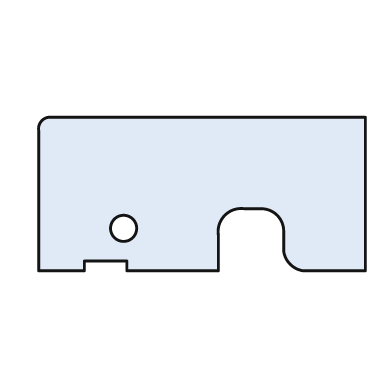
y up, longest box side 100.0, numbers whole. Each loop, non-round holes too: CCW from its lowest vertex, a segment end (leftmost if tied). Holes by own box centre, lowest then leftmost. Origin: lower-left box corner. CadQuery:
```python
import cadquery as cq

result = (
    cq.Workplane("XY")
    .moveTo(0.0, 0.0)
    .lineTo(14.0, 0.0)
    .lineTo(14.0, 3.0)
    .lineTo(27.0, 3.0)
    .lineTo(27.0, 0.0)
    .lineTo(55.0, 0.0)
    .lineTo(55.0, 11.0)
    .threePointArc((57.0, 17.0), (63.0, 19.0))
    .lineTo(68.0, 19.0)
    .threePointArc((73.0, 17.0), (75.0, 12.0))
    .lineTo(75.0, 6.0)
    .threePointArc((77.0, 2.0), (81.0, 0.0))
    .lineTo(100.0, 0.0)
    .lineTo(100.0, 47.0)
    .lineTo(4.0, 47.0)
    .threePointArc((1.0, 46.0), (0.0, 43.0))
    .close()
    .moveTo(26.0, 13.0)
    .circle(4.0)
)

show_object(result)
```